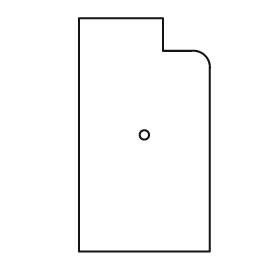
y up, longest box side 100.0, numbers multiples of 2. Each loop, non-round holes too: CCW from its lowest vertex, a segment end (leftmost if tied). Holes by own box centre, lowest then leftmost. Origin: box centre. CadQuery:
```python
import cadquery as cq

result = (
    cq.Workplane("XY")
    .moveTo(-28.0, -50.0)
    .lineTo(28.0, -50.0)
    .lineTo(28.0, 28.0)
    .threePointArc((26.0, 34.0), (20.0, 36.0))
    .lineTo(8.0, 36.0)
    .lineTo(8.0, 50.0)
    .lineTo(-28.0, 50.0)
    .close()
    .moveTo(0.0, 0.0)
    .circle(2.0)
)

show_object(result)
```